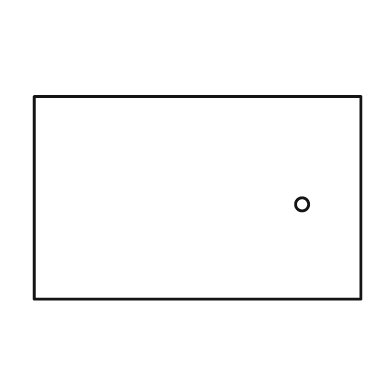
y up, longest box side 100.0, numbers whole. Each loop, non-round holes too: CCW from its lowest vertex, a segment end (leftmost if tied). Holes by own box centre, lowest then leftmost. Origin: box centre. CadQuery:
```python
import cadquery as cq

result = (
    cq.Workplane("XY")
    .moveTo(-50.0, -31.0)
    .lineTo(50.0, -31.0)
    .lineTo(50.0, 31.0)
    .lineTo(-50.0, 31.0)
    .close()
    .moveTo(32.0, -2.0)
    .circle(2.0)
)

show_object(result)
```